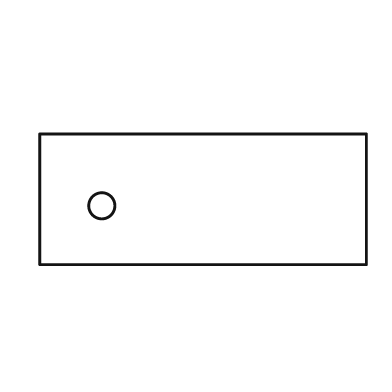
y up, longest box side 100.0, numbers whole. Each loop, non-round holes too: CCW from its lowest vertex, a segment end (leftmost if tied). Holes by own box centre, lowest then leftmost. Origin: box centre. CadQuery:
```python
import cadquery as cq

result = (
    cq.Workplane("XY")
    .moveTo(-50.0, -20.0)
    .lineTo(50.0, -20.0)
    .lineTo(50.0, 20.0)
    .lineTo(-50.0, 20.0)
    .close()
    .moveTo(-31.0, -2.0)
    .circle(4.0)
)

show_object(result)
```